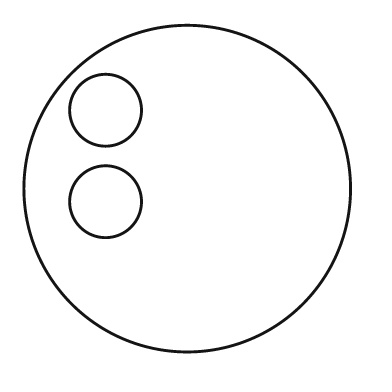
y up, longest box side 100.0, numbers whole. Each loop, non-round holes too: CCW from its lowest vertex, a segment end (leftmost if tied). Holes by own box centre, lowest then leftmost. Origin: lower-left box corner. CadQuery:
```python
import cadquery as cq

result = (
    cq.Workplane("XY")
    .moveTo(50.0, 50.0)
    .circle(50.0)
    .moveTo(25.0, 46.0)
    .circle(11.0)
    .moveTo(25.0, 74.0)
    .circle(11.0)
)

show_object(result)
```